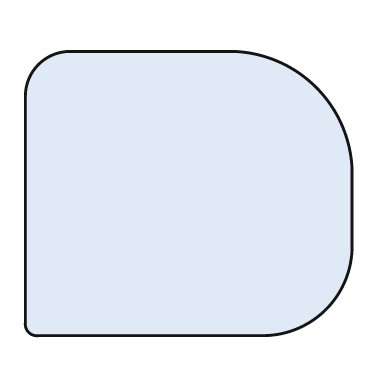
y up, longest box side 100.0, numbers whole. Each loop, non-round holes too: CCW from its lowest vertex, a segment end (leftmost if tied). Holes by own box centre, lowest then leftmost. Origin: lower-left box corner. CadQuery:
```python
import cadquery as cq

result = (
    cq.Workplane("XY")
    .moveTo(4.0, 0.0)
    .lineTo(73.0, 0.0)
    .threePointArc((92.0, 8.0), (100.0, 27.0))
    .lineTo(100.0, 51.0)
    .threePointArc((89.0, 76.0), (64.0, 87.0))
    .lineTo(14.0, 87.0)
    .threePointArc((4.0, 83.0), (0.0, 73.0))
    .lineTo(0.0, 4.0)
    .threePointArc((1.0, 1.0), (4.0, 0.0))
    .close()
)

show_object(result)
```